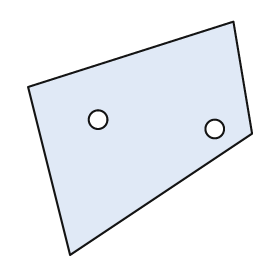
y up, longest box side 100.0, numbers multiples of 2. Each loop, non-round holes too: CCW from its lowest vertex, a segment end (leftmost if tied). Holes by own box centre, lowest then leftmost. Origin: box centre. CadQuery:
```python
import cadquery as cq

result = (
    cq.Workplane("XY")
    .moveTo(-30.0, -50.0)
    .lineTo(48.0, 2.0)
    .lineTo(40.0, 50.0)
    .lineTo(-48.0, 22.0)
    .close()
    .moveTo(32.0, 4.0)
    .circle(4.0)
    .moveTo(-18.0, 8.0)
    .circle(4.0)
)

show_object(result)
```